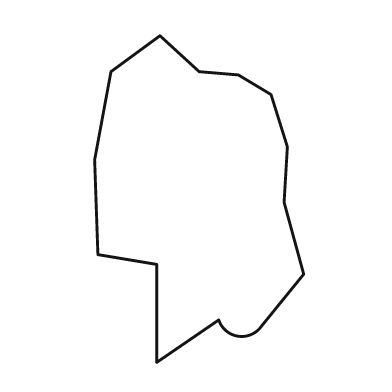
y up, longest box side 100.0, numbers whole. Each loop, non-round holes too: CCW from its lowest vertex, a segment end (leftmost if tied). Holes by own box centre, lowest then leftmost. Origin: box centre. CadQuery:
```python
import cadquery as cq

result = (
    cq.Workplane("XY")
    .moveTo(-13.0, -50.0)
    .lineTo(6.0, -37.0)
    .threePointArc((12.0, -42.0), (19.0, -39.0))
    .lineTo(32.0, -23.0)
    .lineTo(26.0, -1.0)
    .lineTo(27.0, 16.0)
    .lineTo(22.0, 32.0)
    .lineTo(12.0, 38.0)
    .lineTo(0.0, 39.0)
    .lineTo(-12.0, 50.0)
    .lineTo(-27.0, 39.0)
    .lineTo(-32.0, 12.0)
    .lineTo(-31.0, -17.0)
    .lineTo(-13.0, -20.0)
    .close()
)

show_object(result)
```